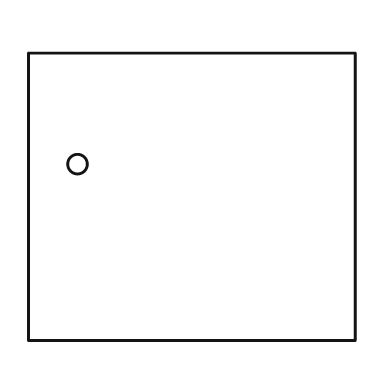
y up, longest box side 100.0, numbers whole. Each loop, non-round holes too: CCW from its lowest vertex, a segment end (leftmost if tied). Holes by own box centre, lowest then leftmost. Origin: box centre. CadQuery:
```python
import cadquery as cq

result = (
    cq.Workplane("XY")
    .moveTo(-50.0, -44.0)
    .lineTo(50.0, -44.0)
    .lineTo(50.0, 44.0)
    .lineTo(-50.0, 44.0)
    .close()
    .moveTo(-35.0, 10.0)
    .circle(3.0)
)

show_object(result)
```